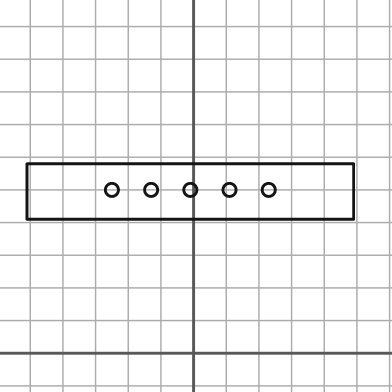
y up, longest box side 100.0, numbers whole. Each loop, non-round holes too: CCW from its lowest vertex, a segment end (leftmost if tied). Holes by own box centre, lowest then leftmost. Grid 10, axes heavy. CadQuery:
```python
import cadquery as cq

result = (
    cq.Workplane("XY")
    .moveTo(-51.0, 41.0)
    .lineTo(49.0, 41.0)
    .lineTo(49.0, 58.0)
    .lineTo(-51.0, 58.0)
    .close()
    .moveTo(-25.0, 50.0)
    .circle(2.0)
    .moveTo(-13.0, 50.0)
    .circle(2.0)
    .moveTo(-1.0, 50.0)
    .circle(2.0)
    .moveTo(11.0, 50.0)
    .circle(2.0)
    .moveTo(23.0, 50.0)
    .circle(2.0)
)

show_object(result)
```